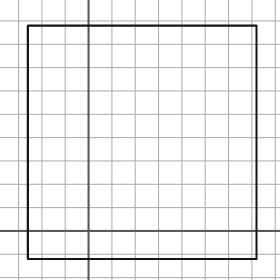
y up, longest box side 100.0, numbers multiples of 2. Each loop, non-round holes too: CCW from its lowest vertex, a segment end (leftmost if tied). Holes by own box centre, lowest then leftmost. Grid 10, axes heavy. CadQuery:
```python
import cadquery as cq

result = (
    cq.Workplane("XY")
    .moveTo(-26.0, -12.0)
    .lineTo(72.0, -12.0)
    .lineTo(72.0, 88.0)
    .lineTo(-26.0, 88.0)
    .close()
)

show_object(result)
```